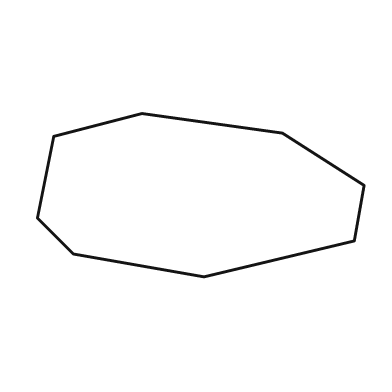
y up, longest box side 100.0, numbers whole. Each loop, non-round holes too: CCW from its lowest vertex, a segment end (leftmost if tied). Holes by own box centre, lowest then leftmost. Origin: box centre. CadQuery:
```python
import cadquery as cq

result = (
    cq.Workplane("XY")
    .moveTo(1.0, -25.0)
    .lineTo(47.0, -14.0)
    .lineTo(50.0, 3.0)
    .lineTo(25.0, 19.0)
    .lineTo(-18.0, 25.0)
    .lineTo(-45.0, 18.0)
    .lineTo(-50.0, -7.0)
    .lineTo(-39.0, -18.0)
    .close()
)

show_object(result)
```